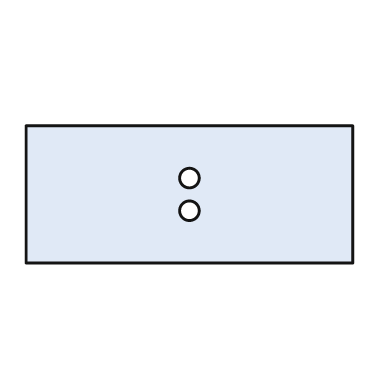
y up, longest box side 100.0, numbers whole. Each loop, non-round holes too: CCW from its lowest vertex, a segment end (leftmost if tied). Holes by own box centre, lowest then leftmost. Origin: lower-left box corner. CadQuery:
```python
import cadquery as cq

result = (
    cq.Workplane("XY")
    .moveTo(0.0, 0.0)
    .lineTo(100.0, 0.0)
    .lineTo(100.0, 42.0)
    .lineTo(0.0, 42.0)
    .close()
    .moveTo(50.0, 16.0)
    .circle(3.0)
    .moveTo(50.0, 26.0)
    .circle(3.0)
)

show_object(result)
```